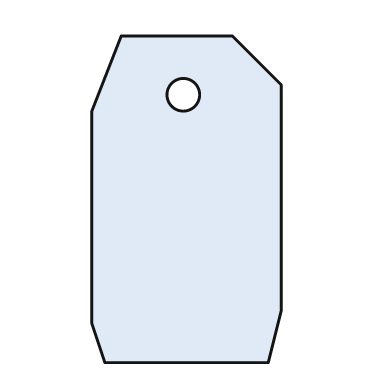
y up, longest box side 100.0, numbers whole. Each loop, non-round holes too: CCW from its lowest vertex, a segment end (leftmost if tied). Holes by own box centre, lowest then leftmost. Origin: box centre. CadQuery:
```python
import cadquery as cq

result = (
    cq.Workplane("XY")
    .moveTo(-25.0, -50.0)
    .lineTo(25.0, -50.0)
    .lineTo(29.0, -34.0)
    .lineTo(29.0, 35.0)
    .lineTo(14.0, 50.0)
    .lineTo(-20.0, 50.0)
    .lineTo(-29.0, 27.0)
    .lineTo(-29.0, -38.0)
    .close()
    .moveTo(-1.0, 32.0)
    .circle(5.0)
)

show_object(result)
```